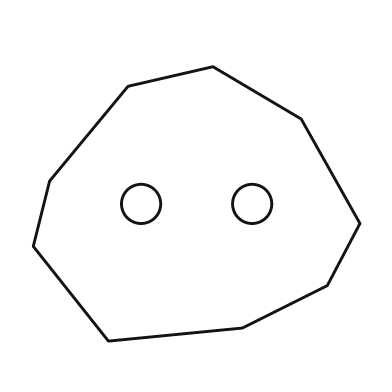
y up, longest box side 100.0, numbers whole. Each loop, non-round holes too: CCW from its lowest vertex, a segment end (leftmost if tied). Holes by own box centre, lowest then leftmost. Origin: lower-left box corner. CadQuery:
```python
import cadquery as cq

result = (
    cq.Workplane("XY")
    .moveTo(23.0, 0.0)
    .lineTo(64.0, 4.0)
    .lineTo(90.0, 17.0)
    .lineTo(100.0, 36.0)
    .lineTo(82.0, 68.0)
    .lineTo(55.0, 84.0)
    .lineTo(29.0, 78.0)
    .lineTo(5.0, 49.0)
    .lineTo(0.0, 29.0)
    .close()
    .moveTo(33.0, 42.0)
    .circle(6.0)
    .moveTo(67.0, 42.0)
    .circle(6.0)
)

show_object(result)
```